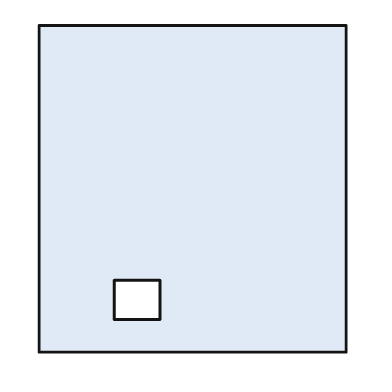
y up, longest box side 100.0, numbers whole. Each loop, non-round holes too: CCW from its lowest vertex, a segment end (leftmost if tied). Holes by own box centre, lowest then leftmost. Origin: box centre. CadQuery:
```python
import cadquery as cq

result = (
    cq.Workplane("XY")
    .moveTo(-47.0, -50.0)
    .lineTo(47.0, -50.0)
    .lineTo(47.0, 50.0)
    .lineTo(-47.0, 50.0)
    .close()
    .moveTo(-24.0, -40.0)
    .lineTo(-10.0, -40.0)
    .lineTo(-10.0, -28.0)
    .lineTo(-24.0, -28.0)
    .close()
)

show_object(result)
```